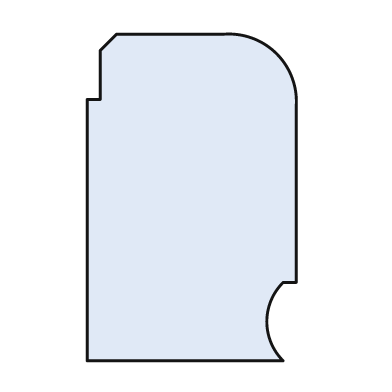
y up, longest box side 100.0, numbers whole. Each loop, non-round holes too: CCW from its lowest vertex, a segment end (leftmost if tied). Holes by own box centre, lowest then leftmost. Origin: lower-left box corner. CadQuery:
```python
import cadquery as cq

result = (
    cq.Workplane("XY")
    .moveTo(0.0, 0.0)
    .lineTo(60.0, 0.0)
    .threePointArc((55.0, 12.0), (60.0, 24.0))
    .lineTo(64.0, 24.0)
    .lineTo(64.0, 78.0)
    .threePointArc((58.0, 94.0), (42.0, 100.0))
    .lineTo(9.0, 100.0)
    .lineTo(4.0, 95.0)
    .lineTo(4.0, 80.0)
    .lineTo(0.0, 80.0)
    .close()
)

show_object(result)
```